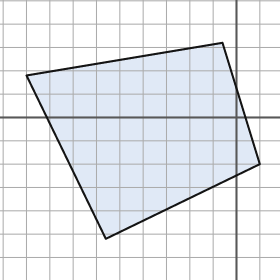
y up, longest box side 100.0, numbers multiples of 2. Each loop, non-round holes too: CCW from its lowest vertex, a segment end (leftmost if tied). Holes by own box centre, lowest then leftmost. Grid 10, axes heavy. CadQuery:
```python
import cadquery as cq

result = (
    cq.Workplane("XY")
    .moveTo(-56.0, -52.0)
    .lineTo(10.0, -20.0)
    .lineTo(-6.0, 32.0)
    .lineTo(-90.0, 18.0)
    .close()
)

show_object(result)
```